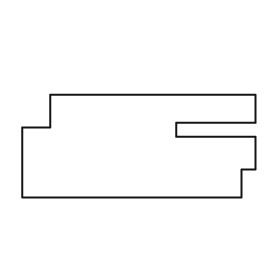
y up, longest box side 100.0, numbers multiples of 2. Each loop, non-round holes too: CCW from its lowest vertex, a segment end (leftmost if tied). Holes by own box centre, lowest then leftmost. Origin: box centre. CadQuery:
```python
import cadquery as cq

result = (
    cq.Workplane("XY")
    .moveTo(-50.0, -22.0)
    .lineTo(44.0, -22.0)
    .lineTo(44.0, -10.0)
    .lineTo(50.0, -10.0)
    .lineTo(50.0, 4.0)
    .lineTo(16.0, 4.0)
    .lineTo(16.0, 10.0)
    .lineTo(50.0, 10.0)
    .lineTo(50.0, 22.0)
    .lineTo(-38.0, 22.0)
    .lineTo(-38.0, 8.0)
    .lineTo(-50.0, 8.0)
    .close()
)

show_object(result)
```